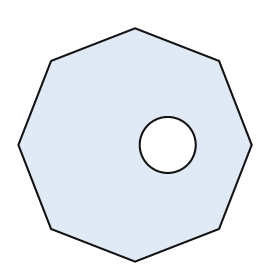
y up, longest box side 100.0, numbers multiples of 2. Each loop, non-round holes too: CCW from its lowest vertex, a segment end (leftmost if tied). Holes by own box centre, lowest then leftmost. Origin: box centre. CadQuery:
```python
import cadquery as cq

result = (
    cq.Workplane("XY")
    .moveTo(0.0, -50.0)
    .lineTo(36.0, -36.0)
    .lineTo(50.0, 0.0)
    .lineTo(36.0, 36.0)
    .lineTo(0.0, 50.0)
    .lineTo(-36.0, 36.0)
    .lineTo(-50.0, 0.0)
    .lineTo(-36.0, -36.0)
    .close()
    .moveTo(14.0, 0.0)
    .circle(12.0)
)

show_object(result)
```